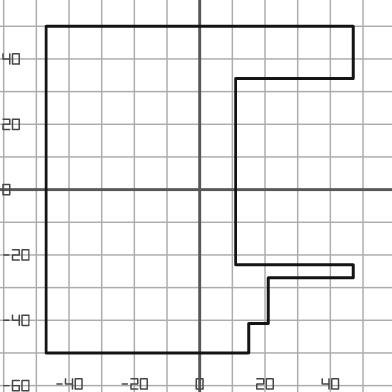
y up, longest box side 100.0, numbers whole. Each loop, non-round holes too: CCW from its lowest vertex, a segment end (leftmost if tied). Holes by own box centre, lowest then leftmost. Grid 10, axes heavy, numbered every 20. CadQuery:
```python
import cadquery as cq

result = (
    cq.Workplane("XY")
    .moveTo(-47.0, -50.0)
    .lineTo(15.0, -50.0)
    .lineTo(15.0, -41.0)
    .lineTo(21.0, -41.0)
    .lineTo(21.0, -27.0)
    .lineTo(47.0, -27.0)
    .lineTo(47.0, -23.0)
    .lineTo(11.0, -23.0)
    .lineTo(11.0, 34.0)
    .lineTo(47.0, 34.0)
    .lineTo(47.0, 50.0)
    .lineTo(-47.0, 50.0)
    .close()
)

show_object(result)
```